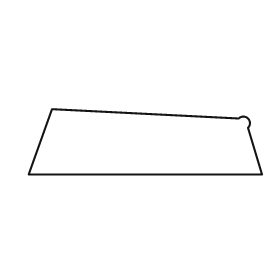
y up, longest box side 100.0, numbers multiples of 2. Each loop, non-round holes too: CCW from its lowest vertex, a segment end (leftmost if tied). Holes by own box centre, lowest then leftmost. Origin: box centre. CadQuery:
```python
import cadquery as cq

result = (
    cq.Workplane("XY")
    .moveTo(-50.0, -14.0)
    .lineTo(50.0, -14.0)
    .lineTo(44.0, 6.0)
    .threePointArc((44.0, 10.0), (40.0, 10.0))
    .lineTo(-40.0, 14.0)
    .close()
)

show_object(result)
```